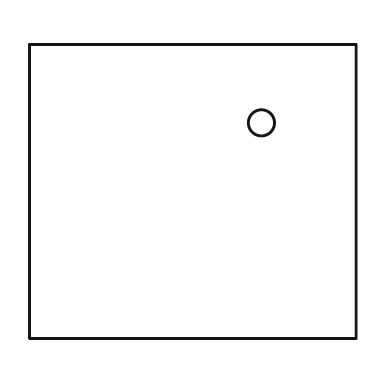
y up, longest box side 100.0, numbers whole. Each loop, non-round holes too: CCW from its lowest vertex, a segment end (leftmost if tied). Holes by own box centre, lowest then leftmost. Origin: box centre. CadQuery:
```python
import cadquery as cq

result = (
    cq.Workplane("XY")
    .moveTo(-50.0, -45.0)
    .lineTo(50.0, -45.0)
    .lineTo(50.0, 45.0)
    .lineTo(-50.0, 45.0)
    .close()
    .moveTo(21.0, 21.0)
    .circle(4.0)
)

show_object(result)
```